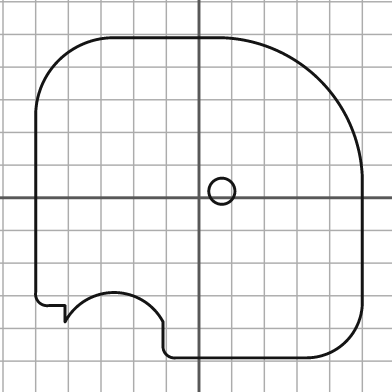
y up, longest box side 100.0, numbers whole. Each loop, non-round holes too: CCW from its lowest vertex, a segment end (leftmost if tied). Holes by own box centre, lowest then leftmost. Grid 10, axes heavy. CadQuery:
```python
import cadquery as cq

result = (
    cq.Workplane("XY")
    .moveTo(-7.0, -49.0)
    .lineTo(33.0, -49.0)
    .threePointArc((45.0, -44.0), (50.0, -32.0))
    .lineTo(50.0, 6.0)
    .threePointArc((37.0, 36.0), (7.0, 49.0))
    .lineTo(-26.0, 49.0)
    .threePointArc((-43.0, 42.0), (-50.0, 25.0))
    .lineTo(-50.0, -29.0)
    .threePointArc((-49.0, -32.0), (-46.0, -33.0))
    .lineTo(-41.0, -33.0)
    .lineTo(-41.0, -38.0)
    .threePointArc((-26.0, -29.0), (-11.0, -38.0))
    .lineTo(-11.0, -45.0)
    .threePointArc((-10.0, -48.0), (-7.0, -49.0))
    .close()
    .moveTo(7.0, 2.0)
    .circle(4.0)
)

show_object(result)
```